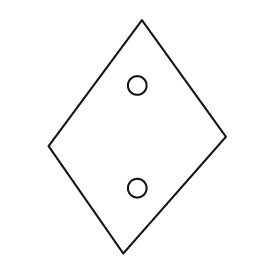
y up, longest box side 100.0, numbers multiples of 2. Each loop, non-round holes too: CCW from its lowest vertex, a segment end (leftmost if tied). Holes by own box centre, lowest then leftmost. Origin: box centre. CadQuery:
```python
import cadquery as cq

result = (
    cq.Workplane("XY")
    .moveTo(-6.0, -50.0)
    .lineTo(38.0, 0.0)
    .lineTo(2.0, 50.0)
    .lineTo(-38.0, -4.0)
    .close()
    .moveTo(0.0, -22.0)
    .circle(4.0)
    .moveTo(0.0, 22.0)
    .circle(4.0)
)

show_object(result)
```